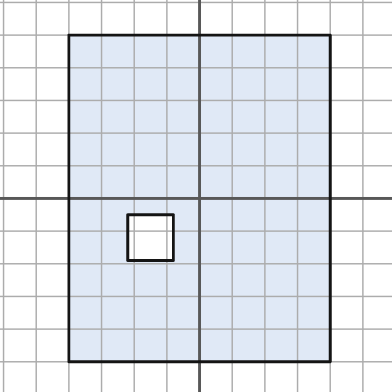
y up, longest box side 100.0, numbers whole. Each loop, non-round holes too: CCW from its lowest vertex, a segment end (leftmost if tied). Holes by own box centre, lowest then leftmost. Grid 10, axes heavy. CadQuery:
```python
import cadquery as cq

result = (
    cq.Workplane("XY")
    .moveTo(-40.0, -50.0)
    .lineTo(40.0, -50.0)
    .lineTo(40.0, 50.0)
    .lineTo(-40.0, 50.0)
    .close()
    .moveTo(-22.0, -19.0)
    .lineTo(-8.0, -19.0)
    .lineTo(-8.0, -5.0)
    .lineTo(-22.0, -5.0)
    .close()
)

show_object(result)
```